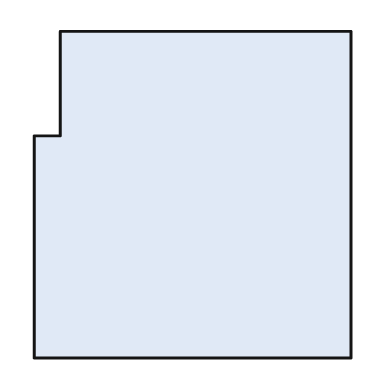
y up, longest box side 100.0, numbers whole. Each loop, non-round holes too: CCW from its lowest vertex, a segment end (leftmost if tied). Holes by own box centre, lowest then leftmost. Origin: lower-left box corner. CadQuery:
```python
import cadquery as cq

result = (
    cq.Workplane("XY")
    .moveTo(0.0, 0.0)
    .lineTo(97.0, 0.0)
    .lineTo(97.0, 100.0)
    .lineTo(8.0, 100.0)
    .lineTo(8.0, 68.0)
    .lineTo(0.0, 68.0)
    .close()
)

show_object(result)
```